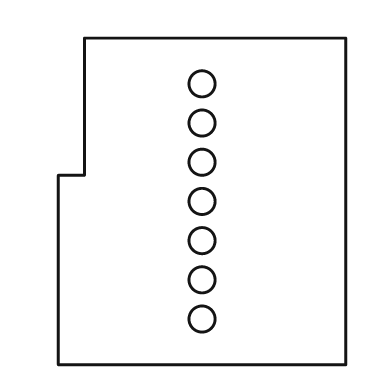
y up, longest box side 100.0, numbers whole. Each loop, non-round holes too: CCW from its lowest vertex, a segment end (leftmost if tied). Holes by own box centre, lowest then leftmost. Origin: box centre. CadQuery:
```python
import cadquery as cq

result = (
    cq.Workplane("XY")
    .moveTo(-44.0, -50.0)
    .lineTo(44.0, -50.0)
    .lineTo(44.0, 50.0)
    .lineTo(-36.0, 50.0)
    .lineTo(-36.0, 8.0)
    .lineTo(-44.0, 8.0)
    .close()
    .moveTo(0.0, -36.0)
    .circle(4.0)
    .moveTo(0.0, -24.0)
    .circle(4.0)
    .moveTo(0.0, -12.0)
    .circle(4.0)
    .moveTo(0.0, 0.0)
    .circle(4.0)
    .moveTo(0.0, 12.0)
    .circle(4.0)
    .moveTo(0.0, 24.0)
    .circle(4.0)
    .moveTo(0.0, 36.0)
    .circle(4.0)
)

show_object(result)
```